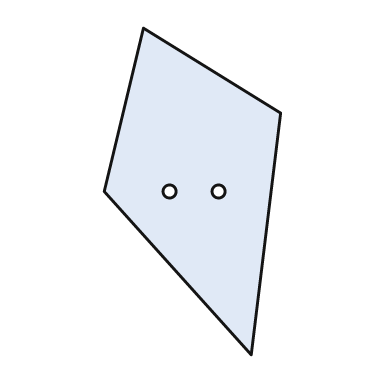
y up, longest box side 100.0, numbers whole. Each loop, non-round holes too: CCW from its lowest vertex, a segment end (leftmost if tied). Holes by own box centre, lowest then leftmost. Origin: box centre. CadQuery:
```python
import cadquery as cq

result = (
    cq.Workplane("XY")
    .moveTo(18.0, -50.0)
    .lineTo(27.0, 24.0)
    .lineTo(-15.0, 50.0)
    .lineTo(-27.0, 0.0)
    .close()
    .moveTo(-7.0, 0.0)
    .circle(2.0)
    .moveTo(8.0, 0.0)
    .circle(2.0)
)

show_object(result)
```